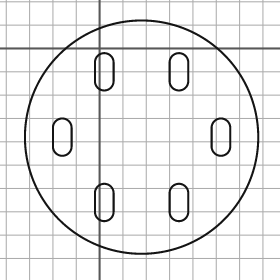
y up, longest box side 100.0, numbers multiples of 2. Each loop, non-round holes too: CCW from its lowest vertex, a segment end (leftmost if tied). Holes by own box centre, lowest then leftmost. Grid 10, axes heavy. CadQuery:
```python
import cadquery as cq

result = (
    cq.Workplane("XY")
    .moveTo(18.0, -38.0)
    .circle(50.0)
    .moveTo(-2.0, -70.0)
    .threePointArc((2.0, -74.0), (6.0, -70.0))
    .lineTo(6.0, -62.0)
    .threePointArc((2.0, -58.0), (-2.0, -62.0))
    .close()
    .moveTo(30.0, -70.0)
    .threePointArc((34.0, -74.0), (38.0, -70.0))
    .lineTo(38.0, -62.0)
    .threePointArc((34.0, -58.0), (30.0, -62.0))
    .close()
    .moveTo(-20.0, -42.0)
    .threePointArc((-16.0, -46.0), (-12.0, -42.0))
    .lineTo(-12.0, -34.0)
    .threePointArc((-16.0, -30.0), (-20.0, -34.0))
    .close()
    .moveTo(48.0, -42.0)
    .threePointArc((52.0, -46.0), (56.0, -42.0))
    .lineTo(56.0, -34.0)
    .threePointArc((52.0, -30.0), (48.0, -34.0))
    .close()
    .moveTo(-2.0, -14.0)
    .threePointArc((2.0, -18.0), (6.0, -14.0))
    .lineTo(6.0, -6.0)
    .threePointArc((2.0, -2.0), (-2.0, -6.0))
    .close()
    .moveTo(30.0, -14.0)
    .threePointArc((34.0, -18.0), (38.0, -14.0))
    .lineTo(38.0, -6.0)
    .threePointArc((34.0, -2.0), (30.0, -6.0))
    .close()
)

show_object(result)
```